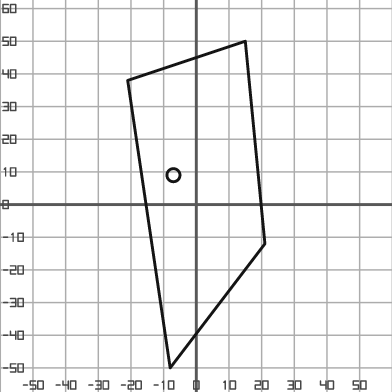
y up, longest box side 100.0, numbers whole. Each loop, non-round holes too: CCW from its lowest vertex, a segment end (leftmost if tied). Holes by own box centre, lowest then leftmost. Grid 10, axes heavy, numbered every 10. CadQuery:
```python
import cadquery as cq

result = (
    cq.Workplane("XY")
    .moveTo(-8.0, -50.0)
    .lineTo(21.0, -12.0)
    .lineTo(15.0, 50.0)
    .lineTo(-21.0, 38.0)
    .close()
    .moveTo(-7.0, 9.0)
    .circle(2.0)
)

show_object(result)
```